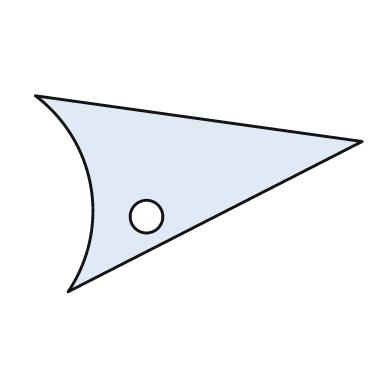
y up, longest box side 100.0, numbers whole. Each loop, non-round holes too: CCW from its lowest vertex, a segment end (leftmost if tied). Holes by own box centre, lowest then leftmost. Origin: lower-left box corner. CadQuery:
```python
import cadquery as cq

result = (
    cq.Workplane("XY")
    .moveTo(10.0, 0.0)
    .lineTo(100.0, 46.0)
    .lineTo(0.0, 60.0)
    .threePointArc((17.0, 32.0), (10.0, 0.0))
    .close()
    .moveTo(34.0, 23.0)
    .circle(5.0)
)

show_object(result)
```